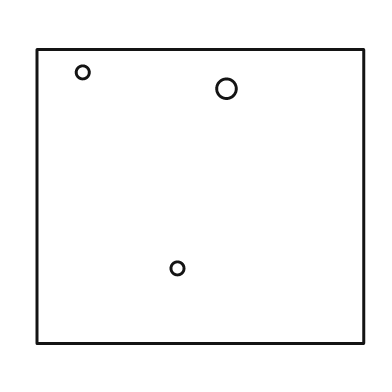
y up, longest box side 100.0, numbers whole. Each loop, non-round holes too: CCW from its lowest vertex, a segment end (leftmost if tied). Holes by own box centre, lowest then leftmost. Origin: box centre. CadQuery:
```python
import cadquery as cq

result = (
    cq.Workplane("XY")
    .moveTo(-50.0, -45.0)
    .lineTo(50.0, -45.0)
    .lineTo(50.0, 45.0)
    .lineTo(-50.0, 45.0)
    .close()
    .moveTo(-7.0, -22.0)
    .circle(2.0)
    .moveTo(8.0, 33.0)
    .circle(3.0)
    .moveTo(-36.0, 38.0)
    .circle(2.0)
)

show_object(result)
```